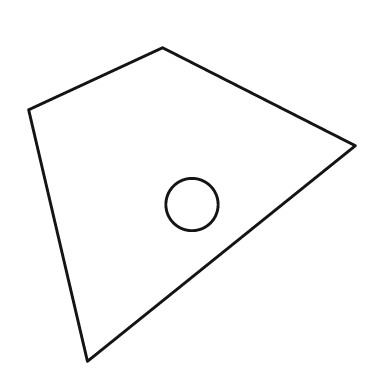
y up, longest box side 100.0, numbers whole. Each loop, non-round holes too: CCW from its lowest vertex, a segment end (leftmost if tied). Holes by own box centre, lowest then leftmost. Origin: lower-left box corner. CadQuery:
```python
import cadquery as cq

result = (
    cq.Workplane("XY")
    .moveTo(18.0, 0.0)
    .lineTo(100.0, 66.0)
    .lineTo(41.0, 96.0)
    .lineTo(0.0, 77.0)
    .close()
    .moveTo(50.0, 48.0)
    .circle(8.0)
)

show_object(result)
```